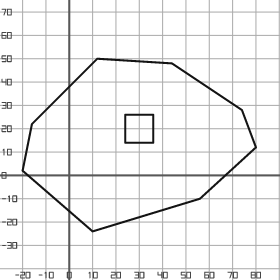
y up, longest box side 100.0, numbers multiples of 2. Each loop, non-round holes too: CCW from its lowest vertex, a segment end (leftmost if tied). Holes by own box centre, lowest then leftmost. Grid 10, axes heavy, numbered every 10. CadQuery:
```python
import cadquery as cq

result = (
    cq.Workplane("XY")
    .moveTo(10.0, -24.0)
    .lineTo(56.0, -10.0)
    .lineTo(80.0, 12.0)
    .lineTo(74.0, 28.0)
    .lineTo(44.0, 48.0)
    .lineTo(12.0, 50.0)
    .lineTo(-16.0, 22.0)
    .lineTo(-20.0, 2.0)
    .close()
    .moveTo(24.0, 14.0)
    .lineTo(36.0, 14.0)
    .lineTo(36.0, 26.0)
    .lineTo(24.0, 26.0)
    .close()
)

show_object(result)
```